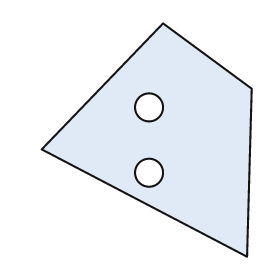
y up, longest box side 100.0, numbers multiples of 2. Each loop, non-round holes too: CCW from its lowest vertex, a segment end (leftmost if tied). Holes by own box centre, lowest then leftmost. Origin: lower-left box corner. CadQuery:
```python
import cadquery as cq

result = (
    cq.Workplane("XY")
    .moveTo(88.0, 0.0)
    .lineTo(90.0, 72.0)
    .lineTo(52.0, 100.0)
    .lineTo(0.0, 46.0)
    .close()
    .moveTo(46.0, 36.0)
    .circle(6.0)
    .moveTo(46.0, 64.0)
    .circle(6.0)
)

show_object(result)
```